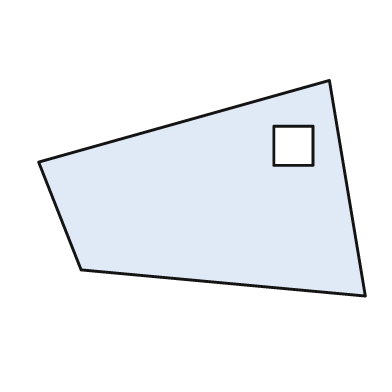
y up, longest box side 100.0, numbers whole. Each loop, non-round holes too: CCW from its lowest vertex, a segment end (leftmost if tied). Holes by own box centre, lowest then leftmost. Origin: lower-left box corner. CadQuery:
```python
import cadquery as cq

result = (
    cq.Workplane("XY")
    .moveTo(100.0, 0.0)
    .lineTo(89.0, 66.0)
    .lineTo(0.0, 41.0)
    .lineTo(13.0, 8.0)
    .close()
    .moveTo(72.0, 40.0)
    .lineTo(84.0, 40.0)
    .lineTo(84.0, 52.0)
    .lineTo(72.0, 52.0)
    .close()
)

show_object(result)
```